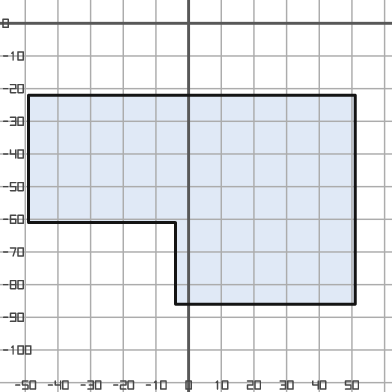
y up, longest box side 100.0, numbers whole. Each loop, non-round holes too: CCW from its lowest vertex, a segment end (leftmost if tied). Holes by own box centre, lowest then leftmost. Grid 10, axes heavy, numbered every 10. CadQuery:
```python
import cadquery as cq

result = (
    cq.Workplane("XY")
    .moveTo(-4.0, -86.0)
    .lineTo(51.0, -86.0)
    .lineTo(51.0, -22.0)
    .lineTo(-49.0, -22.0)
    .lineTo(-49.0, -61.0)
    .lineTo(-4.0, -61.0)
    .close()
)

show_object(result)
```